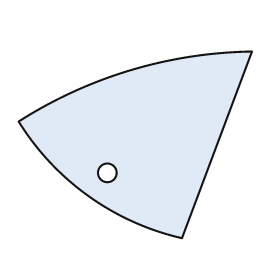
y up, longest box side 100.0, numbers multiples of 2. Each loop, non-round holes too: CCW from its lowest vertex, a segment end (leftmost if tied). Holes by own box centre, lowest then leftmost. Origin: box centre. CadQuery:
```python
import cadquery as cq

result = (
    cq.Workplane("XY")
    .moveTo(20.0, -40.0)
    .lineTo(50.0, 40.0)
    .threePointArc((-2.0, 32.0), (-50.0, 10.0))
    .threePointArc((-20.0, -22.0), (20.0, -40.0))
    .close()
    .moveTo(-12.0, -12.0)
    .circle(4.0)
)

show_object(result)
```